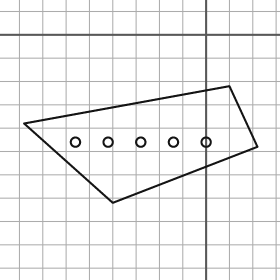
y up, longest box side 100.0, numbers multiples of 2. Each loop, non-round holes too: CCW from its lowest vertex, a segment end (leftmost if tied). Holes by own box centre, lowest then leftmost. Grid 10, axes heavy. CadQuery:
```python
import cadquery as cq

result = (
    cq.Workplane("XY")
    .moveTo(-40.0, -72.0)
    .lineTo(22.0, -48.0)
    .lineTo(10.0, -22.0)
    .lineTo(-78.0, -38.0)
    .close()
    .moveTo(-56.0, -46.0)
    .circle(2.0)
    .moveTo(-42.0, -46.0)
    .circle(2.0)
    .moveTo(-28.0, -46.0)
    .circle(2.0)
    .moveTo(-14.0, -46.0)
    .circle(2.0)
    .moveTo(0.0, -46.0)
    .circle(2.0)
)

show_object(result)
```